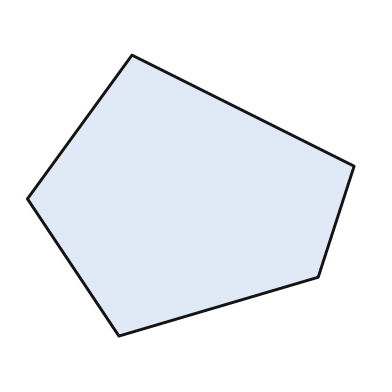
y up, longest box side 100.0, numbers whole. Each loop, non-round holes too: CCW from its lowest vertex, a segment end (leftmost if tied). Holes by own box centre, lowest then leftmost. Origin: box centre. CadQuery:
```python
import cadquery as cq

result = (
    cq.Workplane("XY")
    .moveTo(-22.0, -43.0)
    .lineTo(39.0, -25.0)
    .lineTo(50.0, 9.0)
    .lineTo(-18.0, 43.0)
    .lineTo(-50.0, -1.0)
    .close()
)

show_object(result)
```